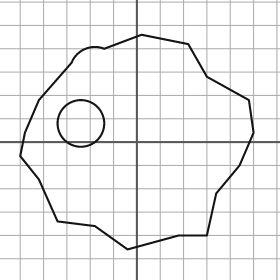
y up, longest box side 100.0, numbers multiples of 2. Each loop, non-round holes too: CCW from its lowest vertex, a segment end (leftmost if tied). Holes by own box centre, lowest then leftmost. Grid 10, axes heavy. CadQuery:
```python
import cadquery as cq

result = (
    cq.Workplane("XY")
    .moveTo(-4.0, -46.0)
    .lineTo(18.0, -40.0)
    .lineTo(30.0, -40.0)
    .lineTo(34.0, -22.0)
    .lineTo(44.0, -10.0)
    .lineTo(50.0, 4.0)
    .lineTo(48.0, 18.0)
    .lineTo(30.0, 28.0)
    .lineTo(22.0, 42.0)
    .lineTo(2.0, 46.0)
    .lineTo(-14.0, 40.0)
    .threePointArc((-22.0, 40.0), (-28.0, 34.0))
    .lineTo(-42.0, 18.0)
    .lineTo(-48.0, 4.0)
    .lineTo(-50.0, -6.0)
    .lineTo(-42.0, -16.0)
    .lineTo(-34.0, -34.0)
    .lineTo(-18.0, -36.0)
    .close()
    .moveTo(-24.0, 8.0)
    .circle(10.0)
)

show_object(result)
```